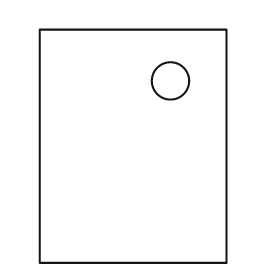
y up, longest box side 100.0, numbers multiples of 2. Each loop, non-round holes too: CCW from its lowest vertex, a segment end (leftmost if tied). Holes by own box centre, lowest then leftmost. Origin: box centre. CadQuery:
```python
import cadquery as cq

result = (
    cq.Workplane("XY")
    .moveTo(-40.0, -50.0)
    .lineTo(40.0, -50.0)
    .lineTo(40.0, 50.0)
    .lineTo(-40.0, 50.0)
    .close()
    .moveTo(16.0, 28.0)
    .circle(8.0)
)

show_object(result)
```